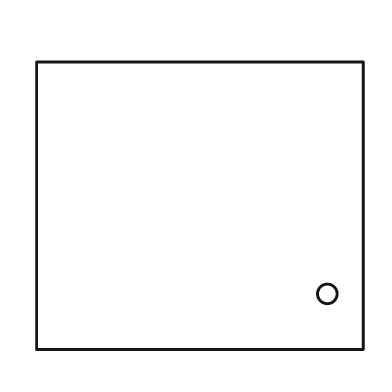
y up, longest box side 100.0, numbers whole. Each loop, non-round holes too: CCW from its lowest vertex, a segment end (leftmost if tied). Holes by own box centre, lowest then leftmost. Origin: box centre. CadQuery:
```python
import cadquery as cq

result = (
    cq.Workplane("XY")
    .moveTo(-50.0, -44.0)
    .lineTo(50.0, -44.0)
    .lineTo(50.0, 44.0)
    .lineTo(-50.0, 44.0)
    .close()
    .moveTo(39.0, -27.0)
    .circle(3.0)
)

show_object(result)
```